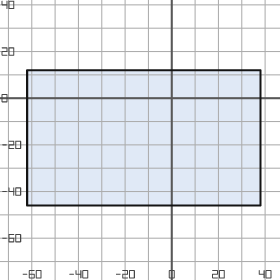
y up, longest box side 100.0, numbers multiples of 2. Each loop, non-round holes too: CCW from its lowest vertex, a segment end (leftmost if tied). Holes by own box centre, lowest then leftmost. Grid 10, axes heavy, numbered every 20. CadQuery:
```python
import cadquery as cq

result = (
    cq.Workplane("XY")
    .moveTo(-62.0, -46.0)
    .lineTo(38.0, -46.0)
    .lineTo(38.0, 12.0)
    .lineTo(-62.0, 12.0)
    .close()
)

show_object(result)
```